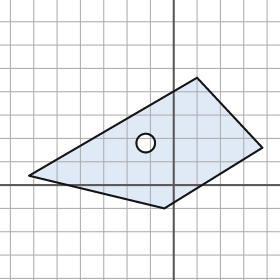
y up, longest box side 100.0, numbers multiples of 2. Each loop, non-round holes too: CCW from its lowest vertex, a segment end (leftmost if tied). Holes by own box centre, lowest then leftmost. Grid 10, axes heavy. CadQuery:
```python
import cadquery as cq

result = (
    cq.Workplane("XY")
    .moveTo(-4.0, -10.0)
    .lineTo(38.0, 16.0)
    .lineTo(10.0, 46.0)
    .lineTo(-62.0, 4.0)
    .close()
    .moveTo(-12.0, 18.0)
    .circle(4.0)
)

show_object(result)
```